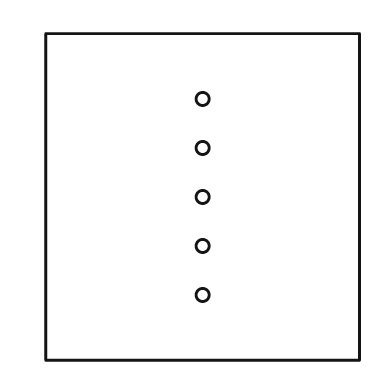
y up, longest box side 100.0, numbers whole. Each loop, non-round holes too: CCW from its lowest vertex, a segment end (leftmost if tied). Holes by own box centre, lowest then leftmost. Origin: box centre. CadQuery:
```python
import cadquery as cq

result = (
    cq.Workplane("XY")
    .moveTo(-48.0, -50.0)
    .lineTo(48.0, -50.0)
    .lineTo(48.0, 50.0)
    .lineTo(-48.0, 50.0)
    .close()
    .moveTo(0.0, -30.0)
    .circle(2.0)
    .moveTo(0.0, -15.0)
    .circle(2.0)
    .moveTo(0.0, 0.0)
    .circle(2.0)
    .moveTo(0.0, 15.0)
    .circle(2.0)
    .moveTo(0.0, 30.0)
    .circle(2.0)
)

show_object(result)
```